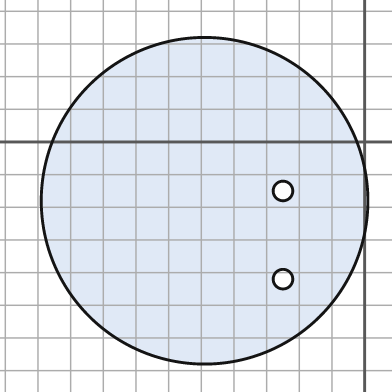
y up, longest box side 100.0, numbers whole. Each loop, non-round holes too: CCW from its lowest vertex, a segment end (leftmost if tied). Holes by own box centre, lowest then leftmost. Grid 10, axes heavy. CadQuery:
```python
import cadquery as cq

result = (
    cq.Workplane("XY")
    .moveTo(-49.0, -18.0)
    .circle(50.0)
    .moveTo(-25.0, -42.0)
    .circle(3.0)
    .moveTo(-25.0, -15.0)
    .circle(3.0)
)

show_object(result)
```